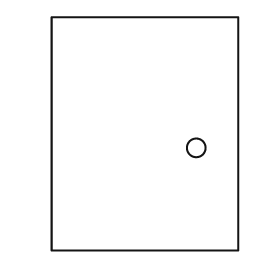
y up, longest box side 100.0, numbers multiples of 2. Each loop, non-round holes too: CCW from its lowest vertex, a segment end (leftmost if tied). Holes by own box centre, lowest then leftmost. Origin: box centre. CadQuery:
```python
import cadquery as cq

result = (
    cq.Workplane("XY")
    .moveTo(-40.0, -50.0)
    .lineTo(40.0, -50.0)
    .lineTo(40.0, 50.0)
    .lineTo(-40.0, 50.0)
    .close()
    .moveTo(22.0, -6.0)
    .circle(4.0)
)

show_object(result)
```